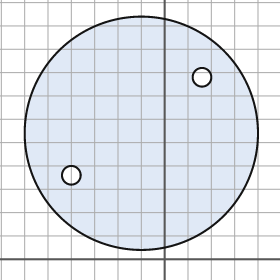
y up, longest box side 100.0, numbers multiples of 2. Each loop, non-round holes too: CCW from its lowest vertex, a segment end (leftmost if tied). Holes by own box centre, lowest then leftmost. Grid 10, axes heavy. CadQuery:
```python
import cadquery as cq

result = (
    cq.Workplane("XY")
    .moveTo(-10.0, 54.0)
    .circle(50.0)
    .moveTo(-40.0, 36.0)
    .circle(4.0)
    .moveTo(16.0, 78.0)
    .circle(4.0)
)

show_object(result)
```